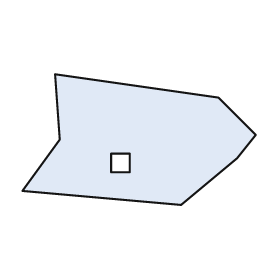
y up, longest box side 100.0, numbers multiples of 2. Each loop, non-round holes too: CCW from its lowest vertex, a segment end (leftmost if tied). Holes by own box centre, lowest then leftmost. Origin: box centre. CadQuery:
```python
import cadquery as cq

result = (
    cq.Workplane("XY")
    .moveTo(18.0, -28.0)
    .lineTo(42.0, -8.0)
    .lineTo(50.0, 2.0)
    .lineTo(34.0, 18.0)
    .lineTo(-36.0, 28.0)
    .lineTo(-34.0, 0.0)
    .lineTo(-50.0, -22.0)
    .close()
    .moveTo(-12.0, -14.0)
    .lineTo(-4.0, -14.0)
    .lineTo(-4.0, -6.0)
    .lineTo(-12.0, -6.0)
    .close()
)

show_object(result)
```